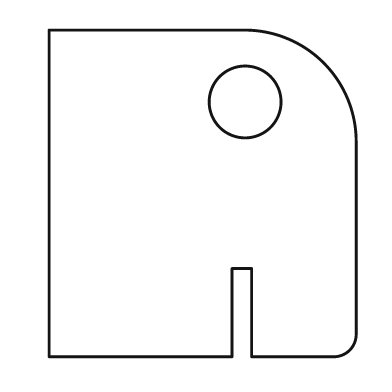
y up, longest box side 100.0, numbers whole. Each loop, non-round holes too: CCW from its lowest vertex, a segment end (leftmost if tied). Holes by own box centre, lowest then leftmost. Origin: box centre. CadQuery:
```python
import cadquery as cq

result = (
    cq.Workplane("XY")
    .moveTo(-47.0, -50.0)
    .lineTo(9.0, -50.0)
    .lineTo(9.0, -23.0)
    .lineTo(15.0, -23.0)
    .lineTo(15.0, -50.0)
    .lineTo(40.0, -50.0)
    .threePointArc((45.0, -48.0), (47.0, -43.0))
    .lineTo(47.0, 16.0)
    .threePointArc((37.0, 40.0), (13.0, 50.0))
    .lineTo(-47.0, 50.0)
    .close()
    .moveTo(13.0, 28.0)
    .circle(11.0)
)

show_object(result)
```